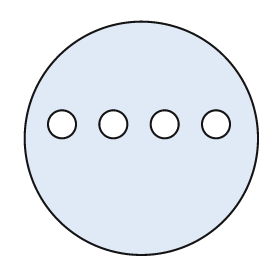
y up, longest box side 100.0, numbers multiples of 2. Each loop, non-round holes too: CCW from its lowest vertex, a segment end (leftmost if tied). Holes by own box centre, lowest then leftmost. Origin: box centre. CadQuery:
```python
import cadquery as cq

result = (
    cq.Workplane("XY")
    .moveTo(0.0, 0.0)
    .circle(50.0)
    .moveTo(-34.0, 6.0)
    .circle(6.0)
    .moveTo(-12.0, 6.0)
    .circle(6.0)
    .moveTo(10.0, 6.0)
    .circle(6.0)
    .moveTo(32.0, 6.0)
    .circle(6.0)
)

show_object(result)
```